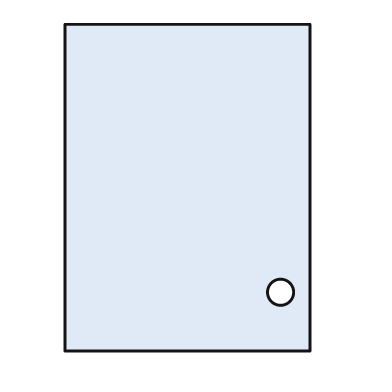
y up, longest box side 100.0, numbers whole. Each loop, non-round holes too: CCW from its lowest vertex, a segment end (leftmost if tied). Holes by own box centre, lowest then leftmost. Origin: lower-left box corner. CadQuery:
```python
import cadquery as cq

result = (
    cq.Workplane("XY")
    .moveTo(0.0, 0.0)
    .lineTo(75.0, 0.0)
    .lineTo(75.0, 100.0)
    .lineTo(0.0, 100.0)
    .close()
    .moveTo(66.0, 18.0)
    .circle(4.0)
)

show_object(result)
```